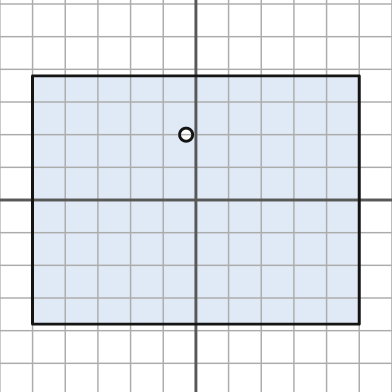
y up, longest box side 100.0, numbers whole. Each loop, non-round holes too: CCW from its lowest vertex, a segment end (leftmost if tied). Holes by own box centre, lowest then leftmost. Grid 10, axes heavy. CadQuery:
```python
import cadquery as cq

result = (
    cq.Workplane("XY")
    .moveTo(-50.0, -38.0)
    .lineTo(50.0, -38.0)
    .lineTo(50.0, 38.0)
    .lineTo(-50.0, 38.0)
    .close()
    .moveTo(-3.0, 20.0)
    .circle(2.0)
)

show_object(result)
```